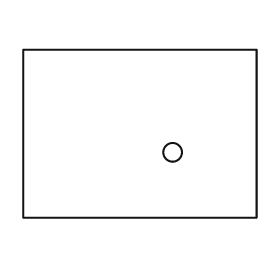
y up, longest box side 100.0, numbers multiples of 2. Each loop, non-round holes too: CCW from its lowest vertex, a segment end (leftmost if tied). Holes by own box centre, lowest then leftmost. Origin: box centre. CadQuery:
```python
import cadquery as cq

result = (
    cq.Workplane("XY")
    .moveTo(-50.0, -36.0)
    .lineTo(50.0, -36.0)
    .lineTo(50.0, 36.0)
    .lineTo(-50.0, 36.0)
    .close()
    .moveTo(14.0, -8.0)
    .circle(4.0)
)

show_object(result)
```